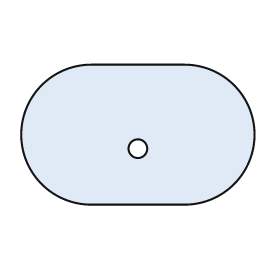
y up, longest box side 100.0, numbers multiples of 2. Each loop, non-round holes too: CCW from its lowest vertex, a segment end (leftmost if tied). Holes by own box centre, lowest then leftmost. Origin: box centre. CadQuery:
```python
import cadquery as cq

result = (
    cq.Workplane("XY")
    .moveTo(-20.0, -30.0)
    .lineTo(20.0, -30.0)
    .threePointArc((50.0, 0.0), (20.0, 30.0))
    .lineTo(-20.0, 30.0)
    .threePointArc((-50.0, 0.0), (-20.0, -30.0))
    .close()
    .moveTo(0.0, -6.0)
    .circle(4.0)
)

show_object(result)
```